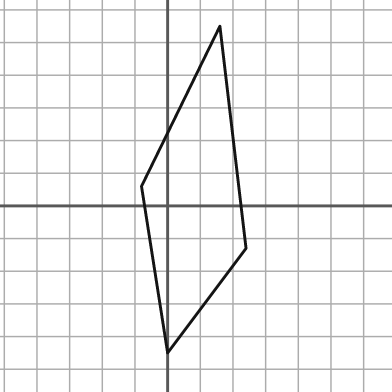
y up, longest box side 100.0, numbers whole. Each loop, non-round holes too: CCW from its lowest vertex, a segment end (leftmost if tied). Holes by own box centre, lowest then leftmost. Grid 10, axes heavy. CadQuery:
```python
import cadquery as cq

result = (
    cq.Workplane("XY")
    .moveTo(0.0, -45.0)
    .lineTo(24.0, -13.0)
    .lineTo(16.0, 55.0)
    .lineTo(-8.0, 6.0)
    .close()
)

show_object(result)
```